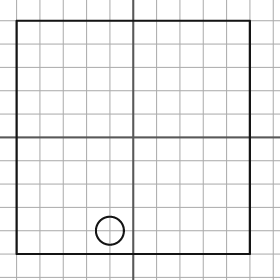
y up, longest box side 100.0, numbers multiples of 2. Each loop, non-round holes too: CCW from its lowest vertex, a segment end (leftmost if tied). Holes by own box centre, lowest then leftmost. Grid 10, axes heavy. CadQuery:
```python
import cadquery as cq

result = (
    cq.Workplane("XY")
    .moveTo(-50.0, -50.0)
    .lineTo(50.0, -50.0)
    .lineTo(50.0, 50.0)
    .lineTo(-50.0, 50.0)
    .close()
    .moveTo(-10.0, -40.0)
    .circle(6.0)
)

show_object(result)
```